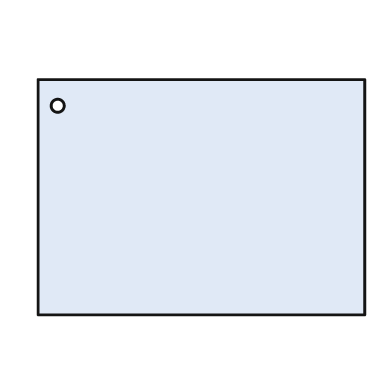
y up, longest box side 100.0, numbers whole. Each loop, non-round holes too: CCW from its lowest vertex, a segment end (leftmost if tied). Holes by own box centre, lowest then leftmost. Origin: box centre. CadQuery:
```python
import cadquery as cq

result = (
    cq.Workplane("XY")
    .moveTo(-50.0, -36.0)
    .lineTo(50.0, -36.0)
    .lineTo(50.0, 36.0)
    .lineTo(-50.0, 36.0)
    .close()
    .moveTo(-44.0, 28.0)
    .circle(2.0)
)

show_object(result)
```